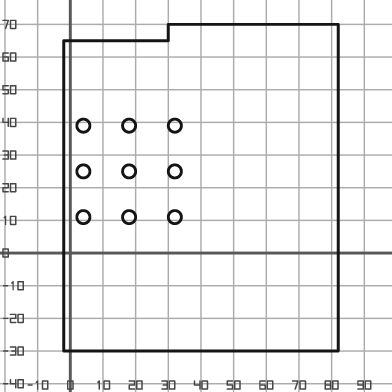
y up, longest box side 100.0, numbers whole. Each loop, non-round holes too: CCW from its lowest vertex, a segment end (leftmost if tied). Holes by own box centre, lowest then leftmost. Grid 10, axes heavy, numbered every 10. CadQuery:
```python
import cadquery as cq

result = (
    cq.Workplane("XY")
    .moveTo(-2.0, -30.0)
    .lineTo(82.0, -30.0)
    .lineTo(82.0, 70.0)
    .lineTo(30.0, 70.0)
    .lineTo(30.0, 65.0)
    .lineTo(-2.0, 65.0)
    .close()
    .moveTo(4.0, 11.0)
    .circle(2.0)
    .moveTo(18.0, 11.0)
    .circle(2.0)
    .moveTo(32.0, 11.0)
    .circle(2.0)
    .moveTo(4.0, 25.0)
    .circle(2.0)
    .moveTo(18.0, 25.0)
    .circle(2.0)
    .moveTo(32.0, 25.0)
    .circle(2.0)
    .moveTo(4.0, 39.0)
    .circle(2.0)
    .moveTo(18.0, 39.0)
    .circle(2.0)
    .moveTo(32.0, 39.0)
    .circle(2.0)
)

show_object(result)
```